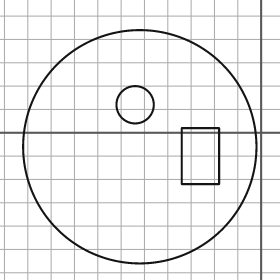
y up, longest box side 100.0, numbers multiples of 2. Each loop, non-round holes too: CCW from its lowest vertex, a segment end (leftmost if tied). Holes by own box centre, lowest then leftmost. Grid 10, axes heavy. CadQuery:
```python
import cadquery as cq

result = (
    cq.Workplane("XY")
    .moveTo(-52.0, -6.0)
    .circle(50.0)
    .moveTo(-34.0, -22.0)
    .lineTo(-18.0, -22.0)
    .lineTo(-18.0, 2.0)
    .lineTo(-34.0, 2.0)
    .close()
    .moveTo(-54.0, 12.0)
    .circle(8.0)
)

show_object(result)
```